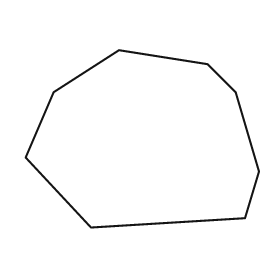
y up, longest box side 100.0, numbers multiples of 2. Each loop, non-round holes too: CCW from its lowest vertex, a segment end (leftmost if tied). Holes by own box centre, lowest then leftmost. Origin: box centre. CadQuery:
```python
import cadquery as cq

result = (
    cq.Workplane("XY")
    .moveTo(-22.0, -38.0)
    .lineTo(44.0, -34.0)
    .lineTo(50.0, -14.0)
    .lineTo(40.0, 20.0)
    .lineTo(28.0, 32.0)
    .lineTo(-10.0, 38.0)
    .lineTo(-38.0, 20.0)
    .lineTo(-50.0, -8.0)
    .close()
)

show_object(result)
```